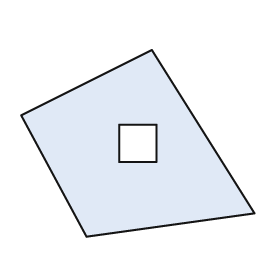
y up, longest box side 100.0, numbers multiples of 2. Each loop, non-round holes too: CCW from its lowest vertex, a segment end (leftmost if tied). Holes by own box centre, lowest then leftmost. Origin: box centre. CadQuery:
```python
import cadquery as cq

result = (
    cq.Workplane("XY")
    .moveTo(-22.0, -40.0)
    .lineTo(50.0, -30.0)
    .lineTo(6.0, 40.0)
    .lineTo(-50.0, 12.0)
    .close()
    .moveTo(-8.0, -8.0)
    .lineTo(8.0, -8.0)
    .lineTo(8.0, 8.0)
    .lineTo(-8.0, 8.0)
    .close()
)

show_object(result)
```